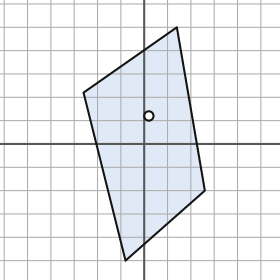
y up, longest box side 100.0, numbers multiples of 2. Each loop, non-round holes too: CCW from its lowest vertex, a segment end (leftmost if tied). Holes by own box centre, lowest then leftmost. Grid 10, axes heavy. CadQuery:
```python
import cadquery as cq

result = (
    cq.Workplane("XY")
    .moveTo(-8.0, -50.0)
    .lineTo(26.0, -20.0)
    .lineTo(14.0, 50.0)
    .lineTo(-26.0, 22.0)
    .close()
    .moveTo(2.0, 12.0)
    .circle(2.0)
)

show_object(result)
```